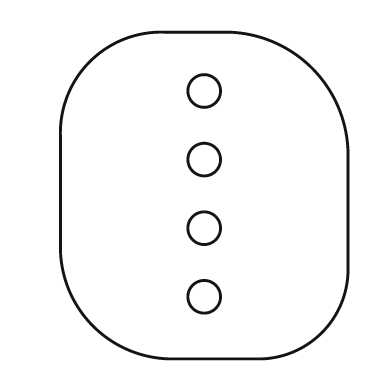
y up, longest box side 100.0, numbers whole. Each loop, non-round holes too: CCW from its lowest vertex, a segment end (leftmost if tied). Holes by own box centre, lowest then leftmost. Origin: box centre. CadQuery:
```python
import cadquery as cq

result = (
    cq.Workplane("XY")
    .moveTo(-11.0, -50.0)
    .lineTo(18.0, -50.0)
    .threePointArc((36.0, -42.0), (44.0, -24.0))
    .lineTo(44.0, 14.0)
    .threePointArc((33.0, 39.0), (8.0, 50.0))
    .lineTo(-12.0, 50.0)
    .threePointArc((-35.0, 41.0), (-44.0, 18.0))
    .lineTo(-44.0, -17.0)
    .threePointArc((-34.0, -40.0), (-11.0, -50.0))
    .close()
    .moveTo(0.0, -31.0)
    .circle(5.0)
    .moveTo(0.0, -10.0)
    .circle(5.0)
    .moveTo(0.0, 11.0)
    .circle(5.0)
    .moveTo(0.0, 32.0)
    .circle(5.0)
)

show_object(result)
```